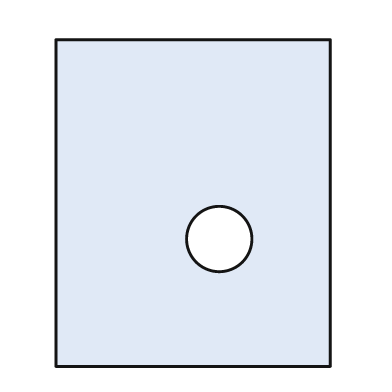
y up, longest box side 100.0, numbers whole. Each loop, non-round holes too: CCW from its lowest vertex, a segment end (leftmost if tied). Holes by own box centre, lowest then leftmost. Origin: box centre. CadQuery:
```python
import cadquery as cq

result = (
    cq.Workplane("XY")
    .moveTo(-42.0, -50.0)
    .lineTo(42.0, -50.0)
    .lineTo(42.0, 50.0)
    .lineTo(-42.0, 50.0)
    .close()
    .moveTo(8.0, -11.0)
    .circle(10.0)
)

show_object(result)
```